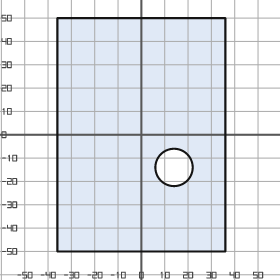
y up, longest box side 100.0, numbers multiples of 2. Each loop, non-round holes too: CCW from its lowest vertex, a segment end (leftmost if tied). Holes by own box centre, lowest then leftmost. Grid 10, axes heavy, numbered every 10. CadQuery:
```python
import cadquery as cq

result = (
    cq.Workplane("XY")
    .moveTo(-36.0, -50.0)
    .lineTo(36.0, -50.0)
    .lineTo(36.0, 50.0)
    .lineTo(-36.0, 50.0)
    .close()
    .moveTo(14.0, -14.0)
    .circle(8.0)
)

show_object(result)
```